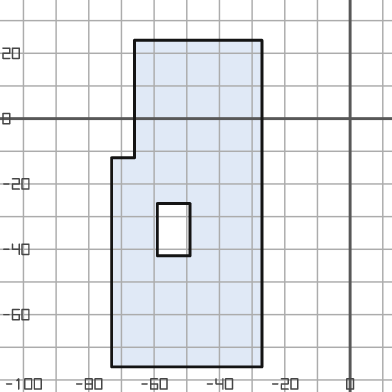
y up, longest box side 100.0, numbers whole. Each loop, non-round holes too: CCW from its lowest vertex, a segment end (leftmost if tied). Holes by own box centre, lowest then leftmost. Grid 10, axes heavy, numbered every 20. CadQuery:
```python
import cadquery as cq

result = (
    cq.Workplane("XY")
    .moveTo(-73.0, -76.0)
    .lineTo(-27.0, -76.0)
    .lineTo(-27.0, 24.0)
    .lineTo(-66.0, 24.0)
    .lineTo(-66.0, -12.0)
    .lineTo(-73.0, -12.0)
    .close()
    .moveTo(-59.0, -42.0)
    .lineTo(-49.0, -42.0)
    .lineTo(-49.0, -26.0)
    .lineTo(-59.0, -26.0)
    .close()
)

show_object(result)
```